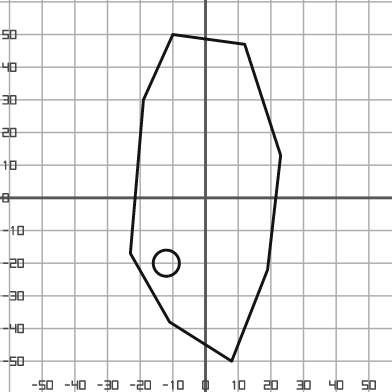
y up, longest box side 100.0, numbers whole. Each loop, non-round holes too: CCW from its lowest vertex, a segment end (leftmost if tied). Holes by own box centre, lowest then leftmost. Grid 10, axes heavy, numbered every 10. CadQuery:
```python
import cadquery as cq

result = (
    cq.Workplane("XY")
    .moveTo(8.0, -50.0)
    .lineTo(19.0, -22.0)
    .lineTo(23.0, 13.0)
    .lineTo(12.0, 47.0)
    .lineTo(-10.0, 50.0)
    .lineTo(-19.0, 30.0)
    .lineTo(-23.0, -17.0)
    .lineTo(-11.0, -38.0)
    .close()
    .moveTo(-12.0, -20.0)
    .circle(4.0)
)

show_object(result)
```